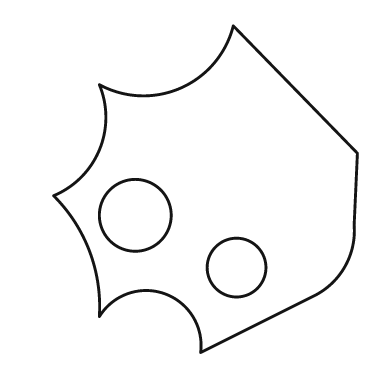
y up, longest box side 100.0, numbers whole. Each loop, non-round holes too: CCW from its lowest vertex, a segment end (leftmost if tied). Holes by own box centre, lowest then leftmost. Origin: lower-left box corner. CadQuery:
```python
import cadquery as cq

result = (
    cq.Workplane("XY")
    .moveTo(45.0, 0.0)
    .lineTo(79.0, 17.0)
    .threePointArc((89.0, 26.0), (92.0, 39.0))
    .lineTo(93.0, 61.0)
    .lineTo(55.0, 100.0)
    .threePointArc((39.0, 81.0), (14.0, 82.0))
    .threePointArc((14.0, 62.0), (0.0, 48.0))
    .threePointArc((11.0, 31.0), (14.0, 11.0))
    .threePointArc((34.0, 18.0), (45.0, 0.0))
    .close()
    .moveTo(56.0, 26.0)
    .circle(9.0)
    .moveTo(25.0, 42.0)
    .circle(11.0)
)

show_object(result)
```